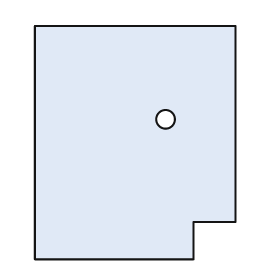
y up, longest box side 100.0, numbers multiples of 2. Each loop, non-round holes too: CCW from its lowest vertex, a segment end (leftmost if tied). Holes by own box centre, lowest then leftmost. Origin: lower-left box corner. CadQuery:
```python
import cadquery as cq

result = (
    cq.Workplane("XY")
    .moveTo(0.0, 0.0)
    .lineTo(68.0, 0.0)
    .lineTo(68.0, 16.0)
    .lineTo(86.0, 16.0)
    .lineTo(86.0, 100.0)
    .lineTo(0.0, 100.0)
    .close()
    .moveTo(56.0, 60.0)
    .circle(4.0)
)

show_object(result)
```